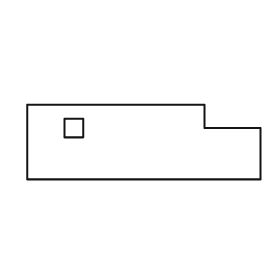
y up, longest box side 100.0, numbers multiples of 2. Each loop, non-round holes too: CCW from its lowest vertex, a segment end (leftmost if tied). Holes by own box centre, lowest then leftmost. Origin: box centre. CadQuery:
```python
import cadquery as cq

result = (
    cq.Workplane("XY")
    .moveTo(-50.0, -16.0)
    .lineTo(50.0, -16.0)
    .lineTo(50.0, 6.0)
    .lineTo(26.0, 6.0)
    .lineTo(26.0, 16.0)
    .lineTo(-50.0, 16.0)
    .close()
    .moveTo(-34.0, 2.0)
    .lineTo(-26.0, 2.0)
    .lineTo(-26.0, 10.0)
    .lineTo(-34.0, 10.0)
    .close()
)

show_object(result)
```